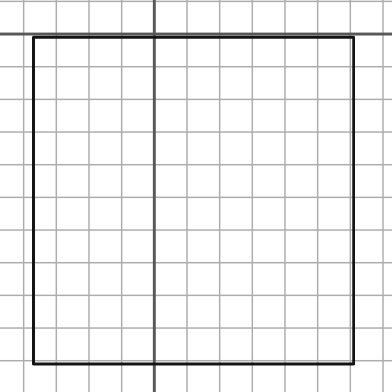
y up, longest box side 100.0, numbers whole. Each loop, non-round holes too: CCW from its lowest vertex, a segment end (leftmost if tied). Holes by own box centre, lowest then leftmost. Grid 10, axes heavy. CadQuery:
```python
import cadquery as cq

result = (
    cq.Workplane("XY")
    .moveTo(-37.0, -101.0)
    .lineTo(61.0, -101.0)
    .lineTo(61.0, -1.0)
    .lineTo(-37.0, -1.0)
    .close()
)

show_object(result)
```